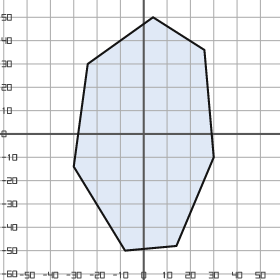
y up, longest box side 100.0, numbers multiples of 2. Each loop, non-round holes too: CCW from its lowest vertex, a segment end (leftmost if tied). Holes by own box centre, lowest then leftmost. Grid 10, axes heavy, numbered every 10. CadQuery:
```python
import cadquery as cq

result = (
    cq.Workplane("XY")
    .moveTo(-8.0, -50.0)
    .lineTo(14.0, -48.0)
    .lineTo(30.0, -10.0)
    .lineTo(26.0, 36.0)
    .lineTo(4.0, 50.0)
    .lineTo(-24.0, 30.0)
    .lineTo(-30.0, -14.0)
    .close()
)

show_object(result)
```